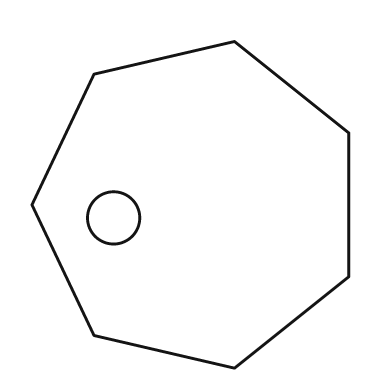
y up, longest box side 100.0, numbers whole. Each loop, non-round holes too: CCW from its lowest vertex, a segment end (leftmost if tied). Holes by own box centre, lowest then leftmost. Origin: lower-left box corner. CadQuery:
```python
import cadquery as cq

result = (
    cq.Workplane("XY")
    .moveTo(62.0, 0.0)
    .lineTo(97.0, 28.0)
    .lineTo(97.0, 72.0)
    .lineTo(62.0, 100.0)
    .lineTo(19.0, 90.0)
    .lineTo(0.0, 50.0)
    .lineTo(19.0, 10.0)
    .close()
    .moveTo(25.0, 46.0)
    .circle(8.0)
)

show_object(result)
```